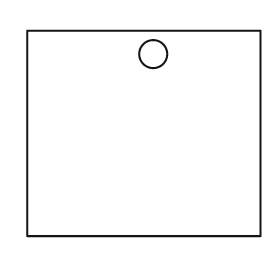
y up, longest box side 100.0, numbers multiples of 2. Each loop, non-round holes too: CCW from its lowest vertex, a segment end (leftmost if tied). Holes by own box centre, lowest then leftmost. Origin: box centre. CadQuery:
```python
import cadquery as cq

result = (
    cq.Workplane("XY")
    .moveTo(-50.0, -44.0)
    .lineTo(50.0, -44.0)
    .lineTo(50.0, 44.0)
    .lineTo(-50.0, 44.0)
    .close()
    .moveTo(4.0, 34.0)
    .circle(6.0)
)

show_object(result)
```